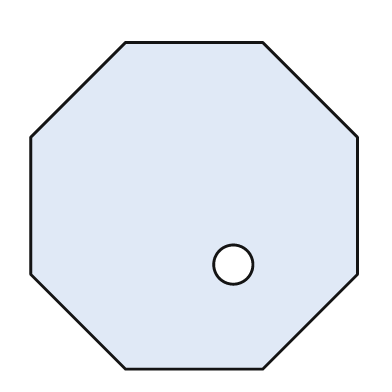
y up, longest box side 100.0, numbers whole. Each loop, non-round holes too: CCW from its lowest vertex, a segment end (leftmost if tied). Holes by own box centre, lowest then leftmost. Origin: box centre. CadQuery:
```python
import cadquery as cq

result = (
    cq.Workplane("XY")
    .moveTo(-21.0, -50.0)
    .lineTo(21.0, -50.0)
    .lineTo(50.0, -21.0)
    .lineTo(50.0, 21.0)
    .lineTo(21.0, 50.0)
    .lineTo(-21.0, 50.0)
    .lineTo(-50.0, 21.0)
    .lineTo(-50.0, -21.0)
    .close()
    .moveTo(12.0, -18.0)
    .circle(6.0)
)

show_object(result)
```